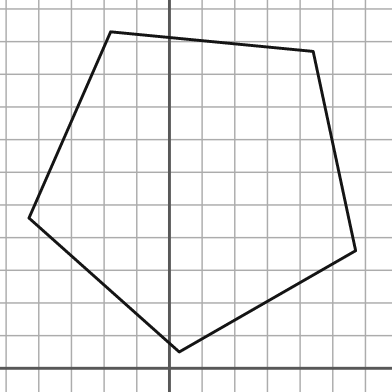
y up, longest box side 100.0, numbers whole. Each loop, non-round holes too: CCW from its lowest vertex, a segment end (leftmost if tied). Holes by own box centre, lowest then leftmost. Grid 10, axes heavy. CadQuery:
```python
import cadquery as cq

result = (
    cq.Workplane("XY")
    .moveTo(3.0, 5.0)
    .lineTo(57.0, 36.0)
    .lineTo(44.0, 97.0)
    .lineTo(-18.0, 103.0)
    .lineTo(-43.0, 46.0)
    .close()
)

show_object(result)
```